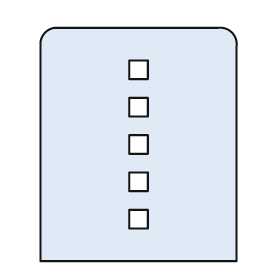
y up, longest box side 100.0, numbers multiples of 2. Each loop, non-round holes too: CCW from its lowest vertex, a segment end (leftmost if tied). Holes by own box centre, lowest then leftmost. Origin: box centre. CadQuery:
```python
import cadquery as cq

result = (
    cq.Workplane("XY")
    .moveTo(-42.0, -50.0)
    .lineTo(42.0, -50.0)
    .lineTo(42.0, 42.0)
    .threePointArc((40.0, 48.0), (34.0, 50.0))
    .lineTo(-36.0, 50.0)
    .threePointArc((-40.0, 48.0), (-42.0, 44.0))
    .close()
    .moveTo(-4.0, -36.0)
    .lineTo(4.0, -36.0)
    .lineTo(4.0, -28.0)
    .lineTo(-4.0, -28.0)
    .close()
    .moveTo(-4.0, -20.0)
    .lineTo(4.0, -20.0)
    .lineTo(4.0, -12.0)
    .lineTo(-4.0, -12.0)
    .close()
    .moveTo(-4.0, -4.0)
    .lineTo(4.0, -4.0)
    .lineTo(4.0, 4.0)
    .lineTo(-4.0, 4.0)
    .close()
    .moveTo(-4.0, 12.0)
    .lineTo(4.0, 12.0)
    .lineTo(4.0, 20.0)
    .lineTo(-4.0, 20.0)
    .close()
    .moveTo(-4.0, 28.0)
    .lineTo(4.0, 28.0)
    .lineTo(4.0, 36.0)
    .lineTo(-4.0, 36.0)
    .close()
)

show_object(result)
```